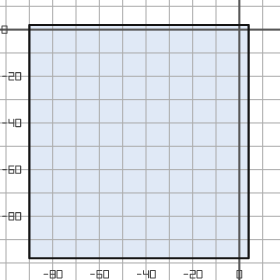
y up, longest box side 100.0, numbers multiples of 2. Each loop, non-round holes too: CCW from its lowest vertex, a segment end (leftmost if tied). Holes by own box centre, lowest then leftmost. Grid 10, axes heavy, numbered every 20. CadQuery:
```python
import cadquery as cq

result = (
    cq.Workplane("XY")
    .moveTo(-90.0, -98.0)
    .lineTo(4.0, -98.0)
    .lineTo(4.0, 2.0)
    .lineTo(-90.0, 2.0)
    .close()
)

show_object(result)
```